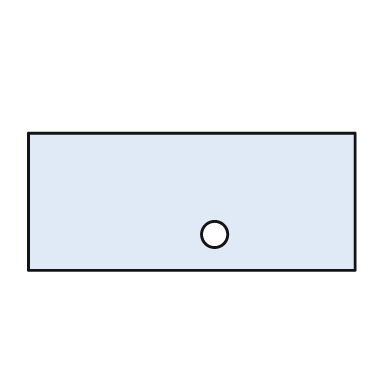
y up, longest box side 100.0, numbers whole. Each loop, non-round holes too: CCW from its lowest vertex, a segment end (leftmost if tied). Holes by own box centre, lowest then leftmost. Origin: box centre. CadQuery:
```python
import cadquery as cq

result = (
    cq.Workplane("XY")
    .moveTo(-50.0, -21.0)
    .lineTo(50.0, -21.0)
    .lineTo(50.0, 21.0)
    .lineTo(-50.0, 21.0)
    .close()
    .moveTo(7.0, -10.0)
    .circle(4.0)
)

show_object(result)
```